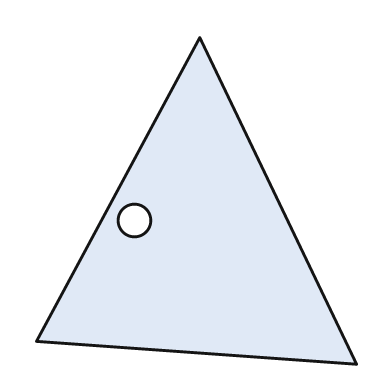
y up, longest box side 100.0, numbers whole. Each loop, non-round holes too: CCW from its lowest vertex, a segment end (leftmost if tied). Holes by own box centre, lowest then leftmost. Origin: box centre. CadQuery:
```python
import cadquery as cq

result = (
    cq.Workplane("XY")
    .moveTo(49.0, -50.0)
    .lineTo(1.0, 50.0)
    .lineTo(-49.0, -43.0)
    .close()
    .moveTo(-19.0, -6.0)
    .circle(5.0)
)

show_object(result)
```